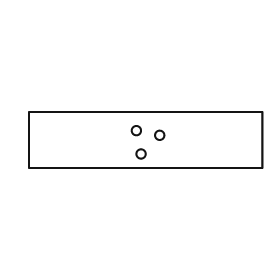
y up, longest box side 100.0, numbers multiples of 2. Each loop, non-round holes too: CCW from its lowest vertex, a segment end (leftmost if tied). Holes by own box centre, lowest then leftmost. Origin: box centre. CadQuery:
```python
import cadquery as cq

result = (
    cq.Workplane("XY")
    .moveTo(-50.0, -12.0)
    .lineTo(50.0, -12.0)
    .lineTo(50.0, 12.0)
    .lineTo(-50.0, 12.0)
    .close()
    .moveTo(-2.0, -6.0)
    .circle(2.0)
    .moveTo(6.0, 2.0)
    .circle(2.0)
    .moveTo(-4.0, 4.0)
    .circle(2.0)
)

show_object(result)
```